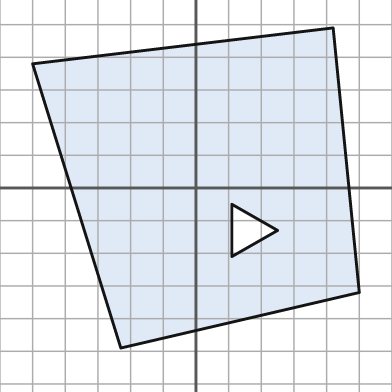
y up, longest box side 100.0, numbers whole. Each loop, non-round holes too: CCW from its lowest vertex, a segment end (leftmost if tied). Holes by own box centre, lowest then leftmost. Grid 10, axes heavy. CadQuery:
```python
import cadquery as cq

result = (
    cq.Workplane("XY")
    .moveTo(-23.0, -49.0)
    .lineTo(50.0, -32.0)
    .lineTo(42.0, 49.0)
    .lineTo(-50.0, 38.0)
    .close()
    .moveTo(11.0, -21.0)
    .lineTo(25.0, -13.0)
    .lineTo(11.0, -5.0)
    .close()
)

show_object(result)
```